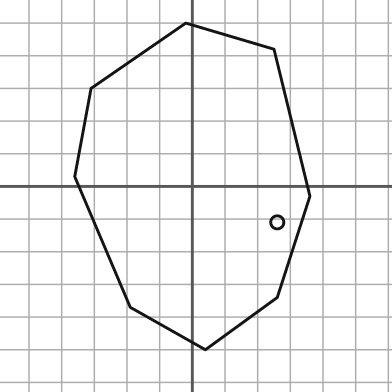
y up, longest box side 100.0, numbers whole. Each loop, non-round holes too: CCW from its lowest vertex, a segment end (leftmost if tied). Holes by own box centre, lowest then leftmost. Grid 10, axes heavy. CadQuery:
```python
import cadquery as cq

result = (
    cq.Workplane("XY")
    .moveTo(4.0, -50.0)
    .lineTo(26.0, -34.0)
    .lineTo(36.0, -3.0)
    .lineTo(25.0, 42.0)
    .lineTo(-2.0, 50.0)
    .lineTo(-31.0, 30.0)
    .lineTo(-36.0, 3.0)
    .lineTo(-19.0, -37.0)
    .close()
    .moveTo(26.0, -11.0)
    .circle(2.0)
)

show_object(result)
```